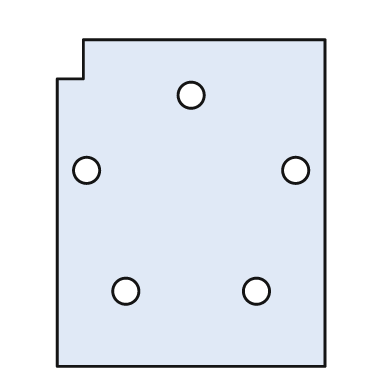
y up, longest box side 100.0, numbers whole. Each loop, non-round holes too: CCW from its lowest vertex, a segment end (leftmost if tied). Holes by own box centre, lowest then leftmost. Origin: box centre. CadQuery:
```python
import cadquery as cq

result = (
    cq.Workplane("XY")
    .moveTo(-41.0, -50.0)
    .lineTo(41.0, -50.0)
    .lineTo(41.0, 50.0)
    .lineTo(-33.0, 50.0)
    .lineTo(-33.0, 38.0)
    .lineTo(-41.0, 38.0)
    .close()
    .moveTo(-20.0, -27.0)
    .circle(4.0)
    .moveTo(20.0, -27.0)
    .circle(4.0)
    .moveTo(-32.0, 10.0)
    .circle(4.0)
    .moveTo(32.0, 10.0)
    .circle(4.0)
    .moveTo(0.0, 33.0)
    .circle(4.0)
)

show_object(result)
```